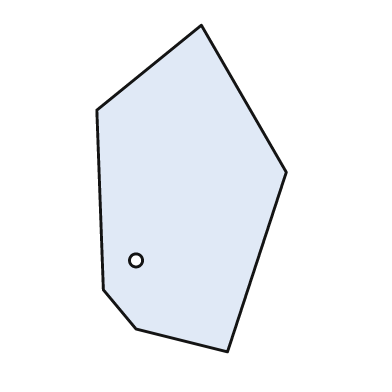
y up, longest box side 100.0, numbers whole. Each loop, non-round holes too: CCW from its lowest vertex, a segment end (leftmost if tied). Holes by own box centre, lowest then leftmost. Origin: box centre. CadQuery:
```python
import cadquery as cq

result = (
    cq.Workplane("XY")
    .moveTo(11.0, -50.0)
    .lineTo(29.0, 5.0)
    .lineTo(3.0, 50.0)
    .lineTo(-29.0, 24.0)
    .lineTo(-27.0, -31.0)
    .lineTo(-17.0, -43.0)
    .close()
    .moveTo(-17.0, -22.0)
    .circle(2.0)
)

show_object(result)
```